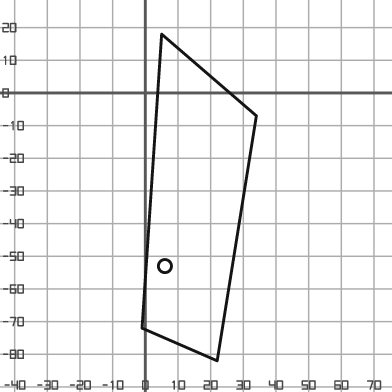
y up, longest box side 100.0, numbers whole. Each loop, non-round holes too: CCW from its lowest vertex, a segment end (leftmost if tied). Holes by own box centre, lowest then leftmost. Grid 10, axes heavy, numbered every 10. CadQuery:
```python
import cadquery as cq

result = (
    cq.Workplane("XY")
    .moveTo(22.0, -82.0)
    .lineTo(34.0, -7.0)
    .lineTo(5.0, 18.0)
    .lineTo(-1.0, -72.0)
    .close()
    .moveTo(6.0, -53.0)
    .circle(2.0)
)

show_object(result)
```